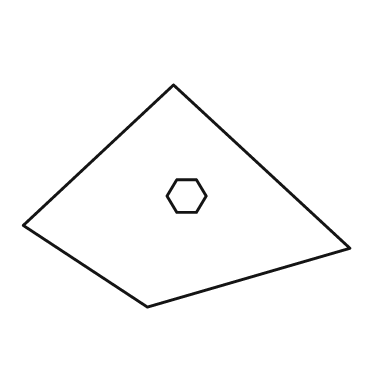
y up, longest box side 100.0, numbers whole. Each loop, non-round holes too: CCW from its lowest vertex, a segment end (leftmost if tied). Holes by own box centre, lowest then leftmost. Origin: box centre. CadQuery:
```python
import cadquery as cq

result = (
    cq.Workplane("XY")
    .moveTo(-12.0, -34.0)
    .lineTo(50.0, -16.0)
    .lineTo(-4.0, 34.0)
    .lineTo(-50.0, -9.0)
    .close()
    .moveTo(-3.0, -5.0)
    .lineTo(3.0, -5.0)
    .lineTo(6.0, 0.0)
    .lineTo(3.0, 5.0)
    .lineTo(-3.0, 5.0)
    .lineTo(-6.0, 0.0)
    .close()
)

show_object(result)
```